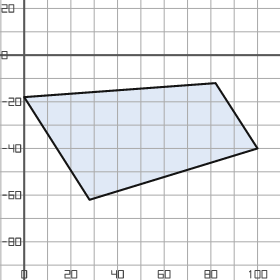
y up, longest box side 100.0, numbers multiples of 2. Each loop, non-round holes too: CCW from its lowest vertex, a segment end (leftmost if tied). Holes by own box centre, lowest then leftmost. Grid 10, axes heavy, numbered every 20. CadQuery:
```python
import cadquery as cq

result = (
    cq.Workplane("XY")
    .moveTo(28.0, -62.0)
    .lineTo(100.0, -40.0)
    .lineTo(82.0, -12.0)
    .lineTo(0.0, -18.0)
    .close()
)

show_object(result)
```